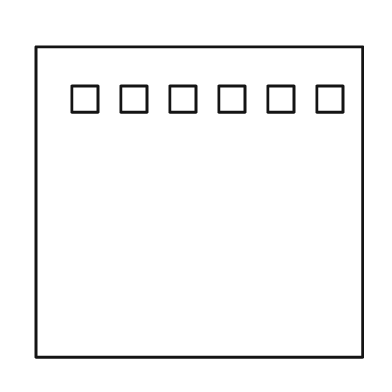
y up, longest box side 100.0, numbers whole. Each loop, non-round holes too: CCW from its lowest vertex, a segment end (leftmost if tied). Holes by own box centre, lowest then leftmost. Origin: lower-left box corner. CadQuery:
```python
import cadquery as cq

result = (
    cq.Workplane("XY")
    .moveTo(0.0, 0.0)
    .lineTo(100.0, 0.0)
    .lineTo(100.0, 95.0)
    .lineTo(0.0, 95.0)
    .close()
    .moveTo(11.0, 75.0)
    .lineTo(19.0, 75.0)
    .lineTo(19.0, 83.0)
    .lineTo(11.0, 83.0)
    .close()
    .moveTo(26.0, 75.0)
    .lineTo(34.0, 75.0)
    .lineTo(34.0, 83.0)
    .lineTo(26.0, 83.0)
    .close()
    .moveTo(41.0, 75.0)
    .lineTo(49.0, 75.0)
    .lineTo(49.0, 83.0)
    .lineTo(41.0, 83.0)
    .close()
    .moveTo(56.0, 75.0)
    .lineTo(64.0, 75.0)
    .lineTo(64.0, 83.0)
    .lineTo(56.0, 83.0)
    .close()
    .moveTo(71.0, 75.0)
    .lineTo(79.0, 75.0)
    .lineTo(79.0, 83.0)
    .lineTo(71.0, 83.0)
    .close()
    .moveTo(86.0, 75.0)
    .lineTo(94.0, 75.0)
    .lineTo(94.0, 83.0)
    .lineTo(86.0, 83.0)
    .close()
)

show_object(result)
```